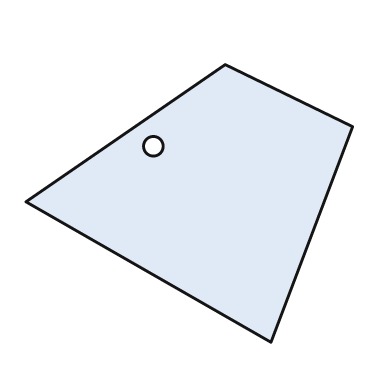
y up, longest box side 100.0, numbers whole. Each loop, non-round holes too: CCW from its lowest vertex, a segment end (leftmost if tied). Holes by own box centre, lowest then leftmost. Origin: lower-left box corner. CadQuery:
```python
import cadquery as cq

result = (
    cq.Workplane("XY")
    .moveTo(75.0, 0.0)
    .lineTo(100.0, 66.0)
    .lineTo(61.0, 85.0)
    .lineTo(0.0, 43.0)
    .close()
    .moveTo(39.0, 60.0)
    .circle(3.0)
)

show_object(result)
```